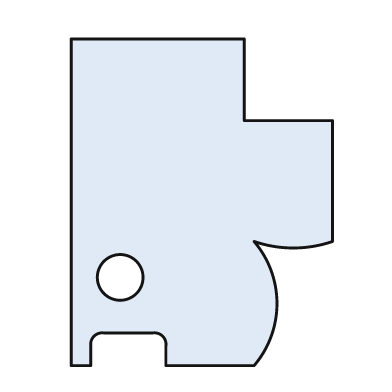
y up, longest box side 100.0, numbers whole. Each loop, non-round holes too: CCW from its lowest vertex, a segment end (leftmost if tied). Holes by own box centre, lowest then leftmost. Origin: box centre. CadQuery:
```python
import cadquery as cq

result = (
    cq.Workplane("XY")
    .moveTo(-40.0, -50.0)
    .lineTo(-34.0, -50.0)
    .lineTo(-34.0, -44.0)
    .threePointArc((-33.0, -41.0), (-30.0, -40.0))
    .lineTo(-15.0, -40.0)
    .threePointArc((-12.0, -41.0), (-11.0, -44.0))
    .lineTo(-11.0, -50.0)
    .lineTo(16.0, -50.0)
    .threePointArc((23.0, -31.0), (16.0, -12.0))
    .threePointArc((28.0, -14.0), (40.0, -12.0))
    .lineTo(40.0, 25.0)
    .lineTo(13.0, 25.0)
    .lineTo(13.0, 50.0)
    .lineTo(-40.0, 50.0)
    .close()
    .moveTo(-25.0, -23.0)
    .circle(7.0)
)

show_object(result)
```